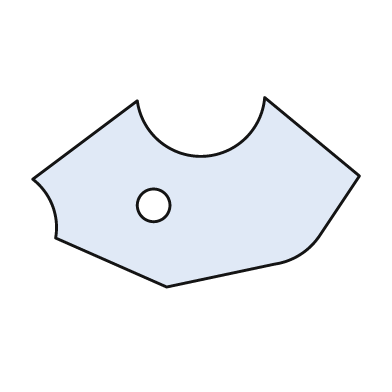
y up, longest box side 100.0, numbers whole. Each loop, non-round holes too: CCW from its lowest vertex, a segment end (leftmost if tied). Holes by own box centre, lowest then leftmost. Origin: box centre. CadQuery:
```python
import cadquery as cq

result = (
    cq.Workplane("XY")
    .moveTo(-9.0, -29.0)
    .lineTo(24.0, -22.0)
    .threePointArc((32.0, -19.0), (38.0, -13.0))
    .lineTo(50.0, 5.0)
    .lineTo(21.0, 29.0)
    .threePointArc((2.0, 11.0), (-18.0, 28.0))
    .lineTo(-50.0, 4.0)
    .threePointArc((-44.0, -4.0), (-43.0, -14.0))
    .close()
    .moveTo(-13.0, -4.0)
    .circle(5.0)
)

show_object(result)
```